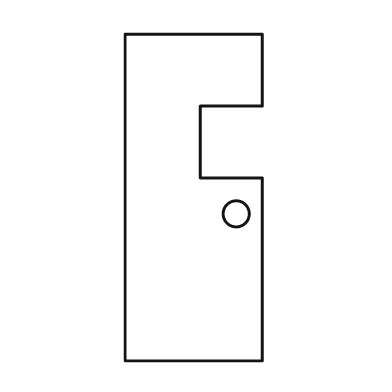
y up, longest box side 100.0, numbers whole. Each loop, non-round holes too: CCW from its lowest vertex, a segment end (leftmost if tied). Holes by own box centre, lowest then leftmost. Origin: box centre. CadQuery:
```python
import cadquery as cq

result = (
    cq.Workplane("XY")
    .moveTo(-21.0, -50.0)
    .lineTo(21.0, -50.0)
    .lineTo(21.0, 6.0)
    .lineTo(2.0, 6.0)
    .lineTo(2.0, 28.0)
    .lineTo(21.0, 28.0)
    .lineTo(21.0, 50.0)
    .lineTo(-21.0, 50.0)
    .close()
    .moveTo(13.0, -5.0)
    .circle(4.0)
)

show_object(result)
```